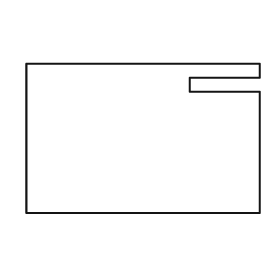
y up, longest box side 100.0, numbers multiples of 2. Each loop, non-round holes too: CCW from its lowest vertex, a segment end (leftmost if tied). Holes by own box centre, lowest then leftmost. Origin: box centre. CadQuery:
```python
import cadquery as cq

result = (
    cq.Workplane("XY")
    .moveTo(-50.0, -32.0)
    .lineTo(50.0, -32.0)
    .lineTo(50.0, 20.0)
    .lineTo(20.0, 20.0)
    .lineTo(20.0, 26.0)
    .lineTo(50.0, 26.0)
    .lineTo(50.0, 32.0)
    .lineTo(-50.0, 32.0)
    .close()
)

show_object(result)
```